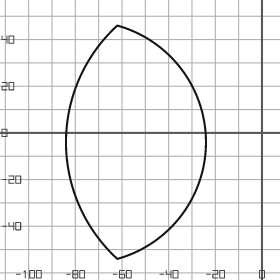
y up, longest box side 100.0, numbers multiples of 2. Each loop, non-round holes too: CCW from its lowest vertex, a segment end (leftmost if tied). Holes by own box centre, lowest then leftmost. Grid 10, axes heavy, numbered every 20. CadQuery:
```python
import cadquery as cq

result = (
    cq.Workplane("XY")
    .moveTo(-62.0, -54.0)
    .threePointArc((-24.0, -4.0), (-62.0, 46.0))
    .threePointArc((-84.0, -4.0), (-62.0, -54.0))
    .close()
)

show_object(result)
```